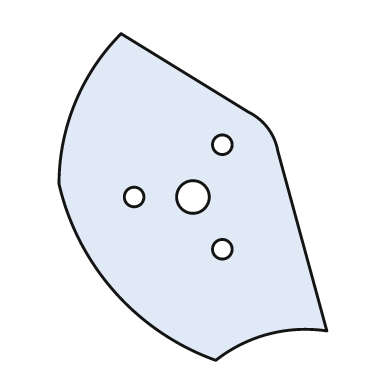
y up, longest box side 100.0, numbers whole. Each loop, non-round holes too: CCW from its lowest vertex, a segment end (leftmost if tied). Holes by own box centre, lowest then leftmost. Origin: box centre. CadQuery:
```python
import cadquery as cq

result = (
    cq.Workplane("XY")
    .moveTo(7.0, -50.0)
    .threePointArc((23.0, -42.0), (41.0, -41.0))
    .lineTo(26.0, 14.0)
    .threePointArc((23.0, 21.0), (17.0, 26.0))
    .lineTo(-22.0, 50.0)
    .threePointArc((-36.0, 29.0), (-41.0, 4.0))
    .threePointArc((-24.0, -29.0), (7.0, -50.0))
    .close()
    .moveTo(9.0, -16.0)
    .circle(3.0)
    .moveTo(-18.0, 0.0)
    .circle(3.0)
    .moveTo(0.0, 0.0)
    .circle(5.0)
    .moveTo(9.0, 16.0)
    .circle(3.0)
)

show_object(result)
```